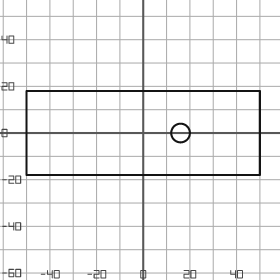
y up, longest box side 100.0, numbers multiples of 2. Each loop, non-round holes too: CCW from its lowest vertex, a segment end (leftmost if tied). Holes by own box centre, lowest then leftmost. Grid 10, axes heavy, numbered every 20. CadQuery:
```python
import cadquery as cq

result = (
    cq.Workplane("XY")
    .moveTo(-50.0, -18.0)
    .lineTo(50.0, -18.0)
    .lineTo(50.0, 18.0)
    .lineTo(-50.0, 18.0)
    .close()
    .moveTo(16.0, 0.0)
    .circle(4.0)
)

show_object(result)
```